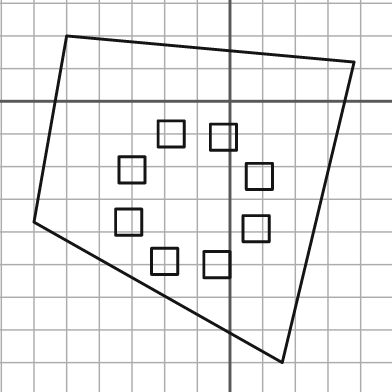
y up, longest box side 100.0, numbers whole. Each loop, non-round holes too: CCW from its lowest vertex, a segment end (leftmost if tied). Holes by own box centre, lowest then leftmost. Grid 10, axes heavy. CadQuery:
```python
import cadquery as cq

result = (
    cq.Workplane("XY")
    .moveTo(16.0, -80.0)
    .lineTo(38.0, 12.0)
    .lineTo(-50.0, 20.0)
    .lineTo(-60.0, -37.0)
    .close()
    .moveTo(-8.0, -54.0)
    .lineTo(0.0, -54.0)
    .lineTo(0.0, -46.0)
    .lineTo(-8.0, -46.0)
    .close()
    .moveTo(-24.0, -53.0)
    .lineTo(-16.0, -53.0)
    .lineTo(-16.0, -45.0)
    .lineTo(-24.0, -45.0)
    .close()
    .moveTo(4.0, -43.0)
    .lineTo(12.0, -43.0)
    .lineTo(12.0, -35.0)
    .lineTo(4.0, -35.0)
    .close()
    .moveTo(-35.0, -41.0)
    .lineTo(-27.0, -41.0)
    .lineTo(-27.0, -33.0)
    .lineTo(-35.0, -33.0)
    .close()
    .moveTo(5.0, -27.0)
    .lineTo(13.0, -27.0)
    .lineTo(13.0, -19.0)
    .lineTo(5.0, -19.0)
    .close()
    .moveTo(-34.0, -25.0)
    .lineTo(-26.0, -25.0)
    .lineTo(-26.0, -17.0)
    .lineTo(-34.0, -17.0)
    .close()
    .moveTo(-6.0, -15.0)
    .lineTo(2.0, -15.0)
    .lineTo(2.0, -7.0)
    .lineTo(-6.0, -7.0)
    .close()
    .moveTo(-22.0, -14.0)
    .lineTo(-14.0, -14.0)
    .lineTo(-14.0, -6.0)
    .lineTo(-22.0, -6.0)
    .close()
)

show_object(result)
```